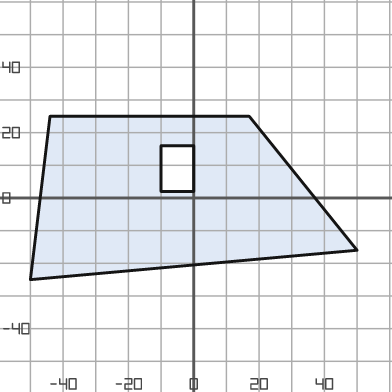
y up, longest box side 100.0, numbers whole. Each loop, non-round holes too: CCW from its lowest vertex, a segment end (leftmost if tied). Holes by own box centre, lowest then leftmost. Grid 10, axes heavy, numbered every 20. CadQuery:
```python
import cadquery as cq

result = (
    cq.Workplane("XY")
    .moveTo(-50.0, -25.0)
    .lineTo(50.0, -16.0)
    .lineTo(17.0, 25.0)
    .lineTo(-44.0, 25.0)
    .close()
    .moveTo(-10.0, 2.0)
    .lineTo(0.0, 2.0)
    .lineTo(0.0, 16.0)
    .lineTo(-10.0, 16.0)
    .close()
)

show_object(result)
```